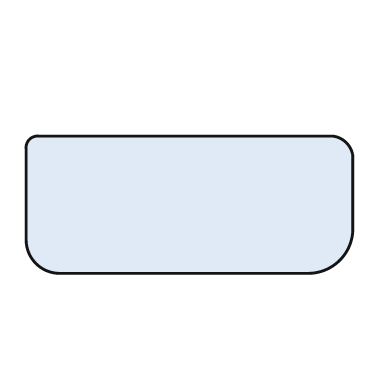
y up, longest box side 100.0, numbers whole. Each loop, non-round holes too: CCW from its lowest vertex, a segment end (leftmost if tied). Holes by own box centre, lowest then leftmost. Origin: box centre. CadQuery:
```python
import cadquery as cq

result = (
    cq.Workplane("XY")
    .moveTo(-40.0, -21.0)
    .lineTo(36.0, -21.0)
    .threePointArc((46.0, -17.0), (50.0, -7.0))
    .lineTo(50.0, 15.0)
    .threePointArc((48.0, 19.0), (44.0, 21.0))
    .lineTo(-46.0, 21.0)
    .threePointArc((-49.0, 20.0), (-50.0, 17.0))
    .lineTo(-50.0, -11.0)
    .threePointArc((-47.0, -18.0), (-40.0, -21.0))
    .close()
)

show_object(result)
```